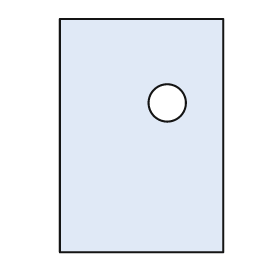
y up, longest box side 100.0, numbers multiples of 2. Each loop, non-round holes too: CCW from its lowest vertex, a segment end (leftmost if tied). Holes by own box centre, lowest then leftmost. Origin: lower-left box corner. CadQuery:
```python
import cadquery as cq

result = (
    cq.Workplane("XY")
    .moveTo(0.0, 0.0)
    .lineTo(70.0, 0.0)
    .lineTo(70.0, 100.0)
    .lineTo(0.0, 100.0)
    .close()
    .moveTo(46.0, 64.0)
    .circle(8.0)
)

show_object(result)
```